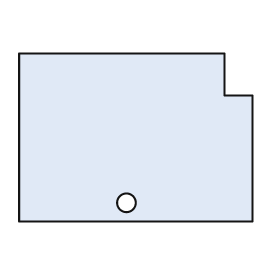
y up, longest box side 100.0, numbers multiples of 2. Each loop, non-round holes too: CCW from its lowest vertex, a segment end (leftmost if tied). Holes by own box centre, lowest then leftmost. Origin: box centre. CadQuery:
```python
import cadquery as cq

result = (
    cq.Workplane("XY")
    .moveTo(-50.0, -36.0)
    .lineTo(50.0, -36.0)
    .lineTo(50.0, 18.0)
    .lineTo(38.0, 18.0)
    .lineTo(38.0, 36.0)
    .lineTo(-50.0, 36.0)
    .close()
    .moveTo(-4.0, -28.0)
    .circle(4.0)
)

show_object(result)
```